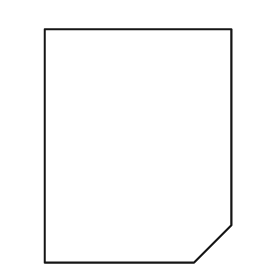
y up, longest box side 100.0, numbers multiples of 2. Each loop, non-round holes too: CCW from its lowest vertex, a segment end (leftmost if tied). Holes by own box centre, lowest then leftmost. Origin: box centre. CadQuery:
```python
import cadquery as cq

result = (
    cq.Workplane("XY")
    .moveTo(-40.0, -50.0)
    .lineTo(24.0, -50.0)
    .lineTo(40.0, -34.0)
    .lineTo(40.0, 50.0)
    .lineTo(-40.0, 50.0)
    .close()
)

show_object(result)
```